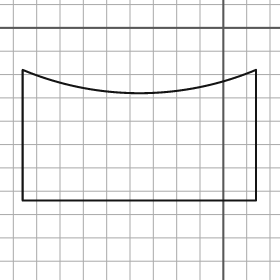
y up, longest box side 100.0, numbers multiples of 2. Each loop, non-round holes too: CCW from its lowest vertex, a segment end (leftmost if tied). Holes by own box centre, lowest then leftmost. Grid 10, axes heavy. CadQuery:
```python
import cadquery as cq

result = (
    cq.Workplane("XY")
    .moveTo(-86.0, -74.0)
    .lineTo(14.0, -74.0)
    .lineTo(14.0, -18.0)
    .threePointArc((-36.0, -28.0), (-86.0, -18.0))
    .close()
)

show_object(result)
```